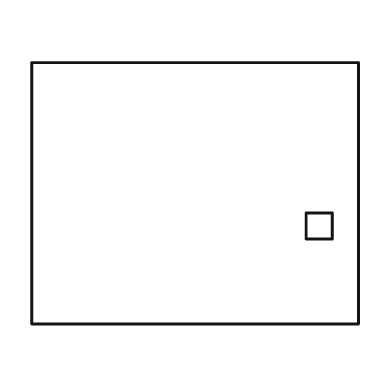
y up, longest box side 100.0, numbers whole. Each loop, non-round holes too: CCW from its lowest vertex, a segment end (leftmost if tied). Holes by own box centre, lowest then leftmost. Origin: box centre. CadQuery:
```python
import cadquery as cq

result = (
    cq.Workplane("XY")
    .moveTo(-50.0, -40.0)
    .lineTo(50.0, -40.0)
    .lineTo(50.0, 40.0)
    .lineTo(-50.0, 40.0)
    .close()
    .moveTo(34.0, -14.0)
    .lineTo(42.0, -14.0)
    .lineTo(42.0, -6.0)
    .lineTo(34.0, -6.0)
    .close()
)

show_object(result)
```